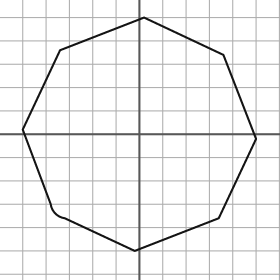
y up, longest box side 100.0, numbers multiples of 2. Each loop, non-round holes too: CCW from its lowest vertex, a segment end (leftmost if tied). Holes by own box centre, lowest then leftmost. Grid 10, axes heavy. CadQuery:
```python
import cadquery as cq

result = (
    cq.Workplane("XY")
    .moveTo(-2.0, -50.0)
    .lineTo(34.0, -36.0)
    .lineTo(50.0, -2.0)
    .lineTo(36.0, 34.0)
    .lineTo(2.0, 50.0)
    .lineTo(-34.0, 36.0)
    .lineTo(-50.0, 2.0)
    .lineTo(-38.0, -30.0)
    .threePointArc((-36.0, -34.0), (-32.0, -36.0))
    .close()
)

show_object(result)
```